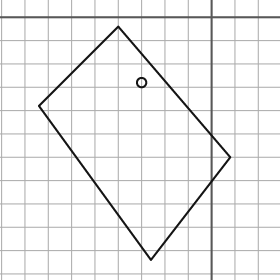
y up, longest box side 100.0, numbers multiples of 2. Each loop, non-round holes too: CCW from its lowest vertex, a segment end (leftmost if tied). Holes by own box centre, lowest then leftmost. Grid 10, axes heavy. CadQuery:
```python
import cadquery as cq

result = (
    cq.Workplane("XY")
    .moveTo(-26.0, -104.0)
    .lineTo(8.0, -60.0)
    .lineTo(-40.0, -4.0)
    .lineTo(-74.0, -38.0)
    .close()
    .moveTo(-30.0, -28.0)
    .circle(2.0)
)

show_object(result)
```